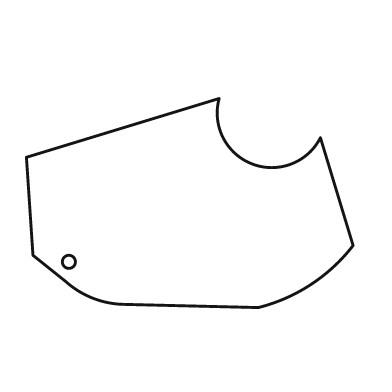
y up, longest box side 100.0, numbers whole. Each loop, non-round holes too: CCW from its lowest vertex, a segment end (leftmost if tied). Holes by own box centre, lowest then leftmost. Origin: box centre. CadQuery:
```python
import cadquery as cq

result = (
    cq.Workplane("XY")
    .moveTo(21.0, -32.0)
    .threePointArc((37.0, -25.0), (50.0, -13.0))
    .lineTo(40.0, 20.0)
    .threePointArc((19.0, 12.0), (9.0, 32.0))
    .lineTo(-50.0, 14.0)
    .lineTo(-48.0, -16.0)
    .lineTo(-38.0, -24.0)
    .threePointArc((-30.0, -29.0), (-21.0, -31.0))
    .close()
    .moveTo(-37.0, -18.0)
    .circle(2.0)
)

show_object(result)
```